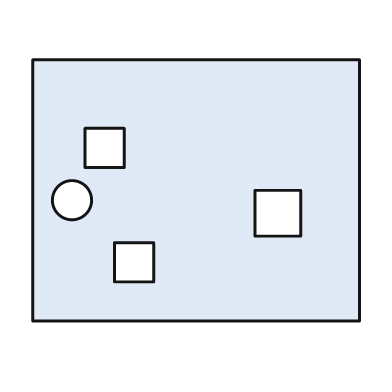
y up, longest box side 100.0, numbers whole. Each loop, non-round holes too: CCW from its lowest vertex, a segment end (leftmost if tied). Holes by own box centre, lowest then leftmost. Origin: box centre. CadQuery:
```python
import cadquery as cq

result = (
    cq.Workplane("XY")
    .moveTo(-50.0, -40.0)
    .lineTo(50.0, -40.0)
    .lineTo(50.0, 40.0)
    .lineTo(-50.0, 40.0)
    .close()
    .moveTo(-25.0, -28.0)
    .lineTo(-13.0, -28.0)
    .lineTo(-13.0, -16.0)
    .lineTo(-25.0, -16.0)
    .close()
    .moveTo(18.0, -14.0)
    .lineTo(32.0, -14.0)
    .lineTo(32.0, 0.0)
    .lineTo(18.0, 0.0)
    .close()
    .moveTo(-38.0, -3.0)
    .circle(6.0)
    .moveTo(-34.0, 7.0)
    .lineTo(-22.0, 7.0)
    .lineTo(-22.0, 19.0)
    .lineTo(-34.0, 19.0)
    .close()
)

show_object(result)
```